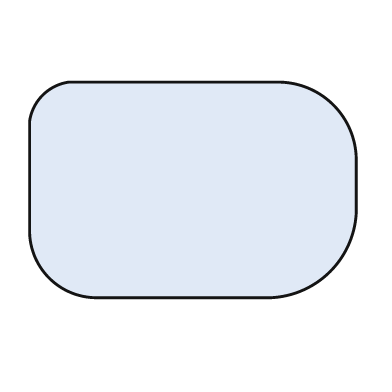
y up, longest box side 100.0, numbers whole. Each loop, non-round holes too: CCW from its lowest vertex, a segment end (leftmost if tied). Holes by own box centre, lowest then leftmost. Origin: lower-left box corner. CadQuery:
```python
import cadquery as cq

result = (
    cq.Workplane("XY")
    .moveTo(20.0, 0.0)
    .lineTo(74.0, 0.0)
    .threePointArc((92.0, 8.0), (100.0, 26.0))
    .lineTo(100.0, 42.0)
    .threePointArc((93.0, 59.0), (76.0, 66.0))
    .lineTo(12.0, 66.0)
    .threePointArc((4.0, 62.0), (0.0, 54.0))
    .lineTo(0.0, 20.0)
    .threePointArc((6.0, 6.0), (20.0, 0.0))
    .close()
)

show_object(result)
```